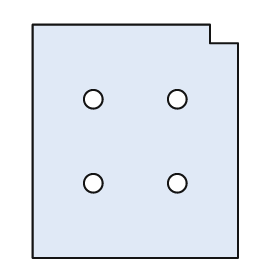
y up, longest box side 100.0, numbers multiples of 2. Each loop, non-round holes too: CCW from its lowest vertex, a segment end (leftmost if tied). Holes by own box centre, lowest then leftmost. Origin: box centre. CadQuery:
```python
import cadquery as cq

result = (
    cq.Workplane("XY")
    .moveTo(-44.0, -50.0)
    .lineTo(44.0, -50.0)
    .lineTo(44.0, 42.0)
    .lineTo(32.0, 42.0)
    .lineTo(32.0, 50.0)
    .lineTo(-44.0, 50.0)
    .close()
    .moveTo(-18.0, -18.0)
    .circle(4.0)
    .moveTo(18.0, -18.0)
    .circle(4.0)
    .moveTo(-18.0, 18.0)
    .circle(4.0)
    .moveTo(18.0, 18.0)
    .circle(4.0)
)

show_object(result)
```